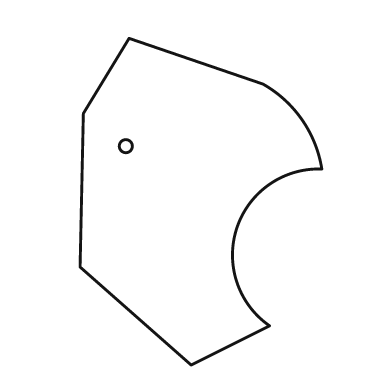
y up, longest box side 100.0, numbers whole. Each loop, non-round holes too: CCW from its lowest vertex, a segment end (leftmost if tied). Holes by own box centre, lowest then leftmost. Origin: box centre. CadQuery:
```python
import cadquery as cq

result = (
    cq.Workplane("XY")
    .moveTo(-3.0, -50.0)
    .lineTo(21.0, -38.0)
    .threePointArc((11.0, -8.0), (37.0, 10.0))
    .threePointArc((31.0, 25.0), (19.0, 36.0))
    .lineTo(-22.0, 50.0)
    .lineTo(-36.0, 27.0)
    .lineTo(-37.0, -20.0)
    .close()
    .moveTo(-23.0, 17.0)
    .circle(2.0)
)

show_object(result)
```